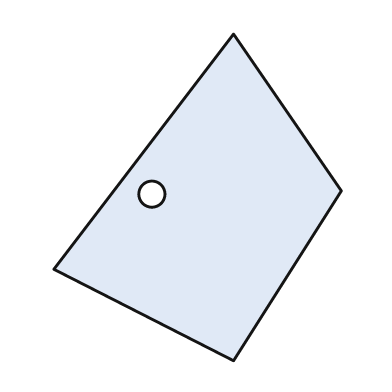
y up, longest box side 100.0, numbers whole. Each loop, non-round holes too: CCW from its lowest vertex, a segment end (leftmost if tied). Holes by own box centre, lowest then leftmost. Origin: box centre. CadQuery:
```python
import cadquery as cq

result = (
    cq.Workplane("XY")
    .moveTo(11.0, -50.0)
    .lineTo(44.0, 2.0)
    .lineTo(11.0, 50.0)
    .lineTo(-44.0, -22.0)
    .close()
    .moveTo(-14.0, 1.0)
    .circle(4.0)
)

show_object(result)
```